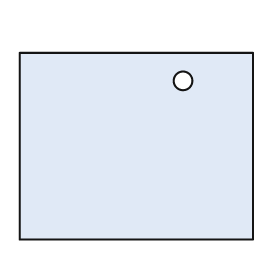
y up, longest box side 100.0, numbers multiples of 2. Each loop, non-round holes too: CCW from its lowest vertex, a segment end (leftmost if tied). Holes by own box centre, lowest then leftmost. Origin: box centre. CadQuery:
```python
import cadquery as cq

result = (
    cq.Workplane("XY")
    .moveTo(-50.0, -40.0)
    .lineTo(50.0, -40.0)
    .lineTo(50.0, 40.0)
    .lineTo(-50.0, 40.0)
    .close()
    .moveTo(20.0, 28.0)
    .circle(4.0)
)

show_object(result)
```